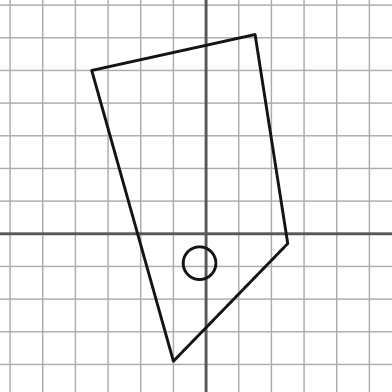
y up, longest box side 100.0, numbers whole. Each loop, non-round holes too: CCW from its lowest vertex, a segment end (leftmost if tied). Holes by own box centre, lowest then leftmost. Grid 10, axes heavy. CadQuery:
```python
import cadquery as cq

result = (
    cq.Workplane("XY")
    .moveTo(-10.0, -39.0)
    .lineTo(25.0, -3.0)
    .lineTo(15.0, 61.0)
    .lineTo(-35.0, 50.0)
    .close()
    .moveTo(-2.0, -9.0)
    .circle(5.0)
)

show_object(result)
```